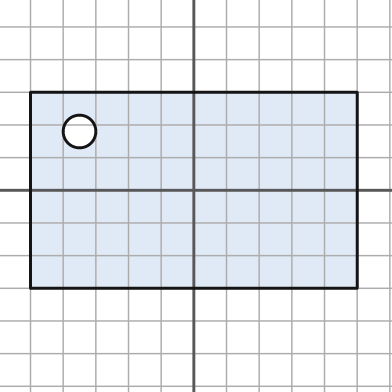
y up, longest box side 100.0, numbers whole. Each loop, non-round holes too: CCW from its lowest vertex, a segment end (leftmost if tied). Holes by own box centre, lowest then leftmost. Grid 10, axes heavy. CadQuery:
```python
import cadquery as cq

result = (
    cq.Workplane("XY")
    .moveTo(-50.0, -30.0)
    .lineTo(50.0, -30.0)
    .lineTo(50.0, 30.0)
    .lineTo(-50.0, 30.0)
    .close()
    .moveTo(-35.0, 18.0)
    .circle(5.0)
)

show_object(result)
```